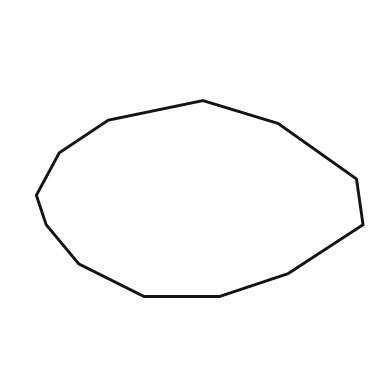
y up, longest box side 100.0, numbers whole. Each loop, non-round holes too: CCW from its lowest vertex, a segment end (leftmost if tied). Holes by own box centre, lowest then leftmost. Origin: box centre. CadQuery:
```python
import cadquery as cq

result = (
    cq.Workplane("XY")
    .moveTo(-17.0, -30.0)
    .lineTo(6.0, -30.0)
    .lineTo(27.0, -23.0)
    .lineTo(50.0, -8.0)
    .lineTo(48.0, 6.0)
    .lineTo(24.0, 23.0)
    .lineTo(1.0, 30.0)
    .lineTo(-28.0, 24.0)
    .lineTo(-43.0, 14.0)
    .lineTo(-50.0, 1.0)
    .lineTo(-47.0, -8.0)
    .lineTo(-37.0, -20.0)
    .close()
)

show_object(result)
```